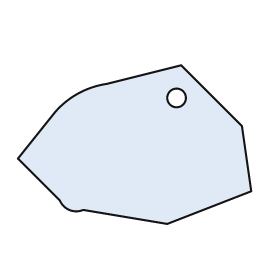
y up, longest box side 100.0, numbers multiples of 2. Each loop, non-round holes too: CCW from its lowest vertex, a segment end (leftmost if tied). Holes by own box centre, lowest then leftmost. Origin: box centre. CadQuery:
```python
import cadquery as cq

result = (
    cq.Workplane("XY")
    .moveTo(14.0, -34.0)
    .lineTo(50.0, -20.0)
    .lineTo(46.0, 8.0)
    .lineTo(20.0, 34.0)
    .lineTo(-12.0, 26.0)
    .threePointArc((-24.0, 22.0), (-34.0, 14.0))
    .lineTo(-50.0, -6.0)
    .lineTo(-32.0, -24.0)
    .threePointArc((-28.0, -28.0), (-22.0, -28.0))
    .close()
    .moveTo(18.0, 20.0)
    .circle(4.0)
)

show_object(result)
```